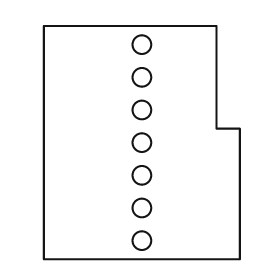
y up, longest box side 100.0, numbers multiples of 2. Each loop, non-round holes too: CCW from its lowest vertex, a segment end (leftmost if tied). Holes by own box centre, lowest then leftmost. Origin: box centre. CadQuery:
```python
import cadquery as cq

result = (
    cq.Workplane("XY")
    .moveTo(-42.0, -50.0)
    .lineTo(42.0, -50.0)
    .lineTo(42.0, 6.0)
    .lineTo(32.0, 6.0)
    .lineTo(32.0, 50.0)
    .lineTo(-42.0, 50.0)
    .close()
    .moveTo(0.0, -42.0)
    .circle(4.0)
    .moveTo(0.0, -28.0)
    .circle(4.0)
    .moveTo(0.0, -14.0)
    .circle(4.0)
    .moveTo(0.0, 0.0)
    .circle(4.0)
    .moveTo(0.0, 14.0)
    .circle(4.0)
    .moveTo(0.0, 28.0)
    .circle(4.0)
    .moveTo(0.0, 42.0)
    .circle(4.0)
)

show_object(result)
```